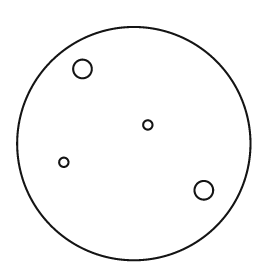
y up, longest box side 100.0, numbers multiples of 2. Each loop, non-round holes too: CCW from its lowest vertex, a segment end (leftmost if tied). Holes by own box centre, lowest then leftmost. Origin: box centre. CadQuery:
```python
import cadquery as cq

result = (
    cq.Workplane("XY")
    .moveTo(0.0, 0.0)
    .circle(50.0)
    .moveTo(30.0, -20.0)
    .circle(4.0)
    .moveTo(-30.0, -8.0)
    .circle(2.0)
    .moveTo(6.0, 8.0)
    .circle(2.0)
    .moveTo(-22.0, 32.0)
    .circle(4.0)
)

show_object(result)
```